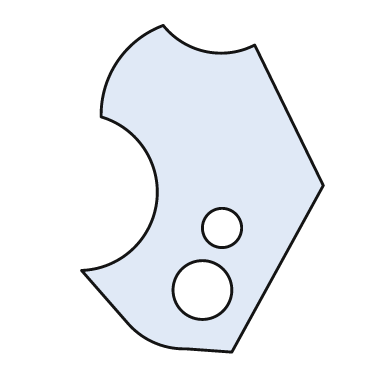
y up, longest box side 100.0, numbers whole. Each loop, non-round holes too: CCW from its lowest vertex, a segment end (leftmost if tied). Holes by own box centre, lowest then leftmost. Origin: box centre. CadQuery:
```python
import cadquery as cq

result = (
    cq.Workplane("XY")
    .moveTo(9.0, -50.0)
    .lineTo(37.0, 1.0)
    .lineTo(16.0, 44.0)
    .threePointArc((1.0, 42.0), (-12.0, 50.0))
    .threePointArc((-26.0, 39.0), (-31.0, 22.0))
    .threePointArc((-14.0, -4.0), (-37.0, -25.0))
    .lineTo(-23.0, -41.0)
    .threePointArc((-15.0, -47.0), (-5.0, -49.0))
    .close()
    .moveTo(0.0, -31.0)
    .circle(9.0)
    .moveTo(6.0, -12.0)
    .circle(6.0)
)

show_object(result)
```